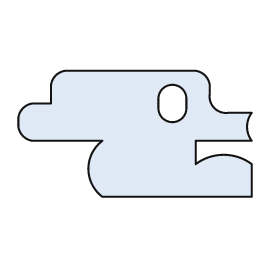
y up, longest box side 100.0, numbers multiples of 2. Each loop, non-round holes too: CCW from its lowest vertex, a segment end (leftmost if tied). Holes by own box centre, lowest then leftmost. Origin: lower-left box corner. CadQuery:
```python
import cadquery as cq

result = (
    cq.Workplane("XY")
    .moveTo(36.0, 0.0)
    .lineTo(100.0, 0.0)
    .lineTo(100.0, 14.0)
    .threePointArc((88.0, 18.0), (76.0, 14.0))
    .lineTo(76.0, 24.0)
    .lineTo(100.0, 24.0)
    .threePointArc((98.0, 30.0), (100.0, 36.0))
    .lineTo(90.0, 36.0)
    .threePointArc((84.0, 38.0), (82.0, 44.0))
    .lineTo(82.0, 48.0)
    .threePointArc((80.0, 52.0), (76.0, 54.0))
    .lineTo(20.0, 54.0)
    .threePointArc((16.0, 52.0), (14.0, 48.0))
    .lineTo(14.0, 40.0)
    .lineTo(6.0, 40.0)
    .threePointArc((2.0, 38.0), (0.0, 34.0))
    .lineTo(0.0, 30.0)
    .threePointArc((2.0, 26.0), (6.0, 24.0))
    .lineTo(36.0, 24.0)
    .threePointArc((30.0, 12.0), (36.0, 0.0))
    .close()
    .moveTo(60.0, 38.0)
    .threePointArc((66.0, 32.0), (72.0, 38.0))
    .lineTo(72.0, 42.0)
    .threePointArc((66.0, 48.0), (60.0, 42.0))
    .close()
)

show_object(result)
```